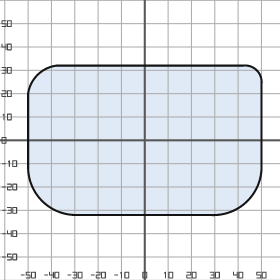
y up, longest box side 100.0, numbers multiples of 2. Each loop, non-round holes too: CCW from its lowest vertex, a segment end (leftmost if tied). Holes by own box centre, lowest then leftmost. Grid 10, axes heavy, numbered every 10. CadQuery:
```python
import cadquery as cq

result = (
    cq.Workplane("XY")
    .moveTo(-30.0, -32.0)
    .lineTo(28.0, -32.0)
    .threePointArc((44.0, -26.0), (50.0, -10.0))
    .lineTo(50.0, 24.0)
    .threePointArc((48.0, 30.0), (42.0, 32.0))
    .lineTo(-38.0, 32.0)
    .threePointArc((-46.0, 28.0), (-50.0, 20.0))
    .lineTo(-50.0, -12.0)
    .threePointArc((-44.0, -26.0), (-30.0, -32.0))
    .close()
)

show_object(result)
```